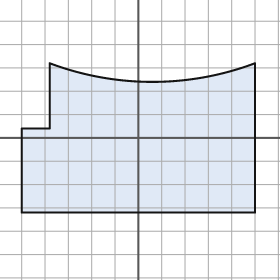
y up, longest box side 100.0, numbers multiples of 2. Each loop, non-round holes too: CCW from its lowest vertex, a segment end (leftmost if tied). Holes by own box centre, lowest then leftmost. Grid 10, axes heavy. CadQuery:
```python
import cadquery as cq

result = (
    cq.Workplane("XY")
    .moveTo(-50.0, -32.0)
    .lineTo(50.0, -32.0)
    .lineTo(50.0, 32.0)
    .threePointArc((6.0, 24.0), (-38.0, 32.0))
    .lineTo(-38.0, 4.0)
    .lineTo(-50.0, 4.0)
    .close()
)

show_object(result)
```